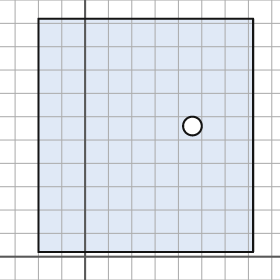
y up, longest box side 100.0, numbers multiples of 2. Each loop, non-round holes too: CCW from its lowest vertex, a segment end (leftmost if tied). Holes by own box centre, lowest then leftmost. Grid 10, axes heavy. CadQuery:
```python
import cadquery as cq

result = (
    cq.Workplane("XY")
    .moveTo(-20.0, 2.0)
    .lineTo(72.0, 2.0)
    .lineTo(72.0, 102.0)
    .lineTo(-20.0, 102.0)
    .close()
    .moveTo(46.0, 56.0)
    .circle(4.0)
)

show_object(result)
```